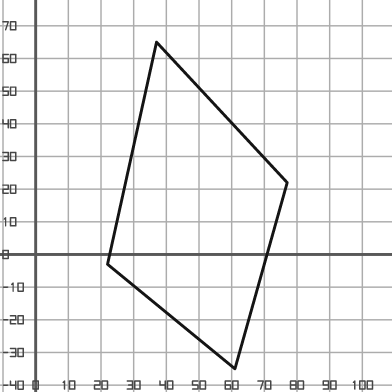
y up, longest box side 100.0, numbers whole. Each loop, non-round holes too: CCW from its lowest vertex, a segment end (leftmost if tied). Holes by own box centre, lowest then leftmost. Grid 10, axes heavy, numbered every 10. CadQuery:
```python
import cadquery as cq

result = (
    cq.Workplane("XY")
    .moveTo(61.0, -35.0)
    .lineTo(77.0, 22.0)
    .lineTo(37.0, 65.0)
    .lineTo(22.0, -3.0)
    .close()
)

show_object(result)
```